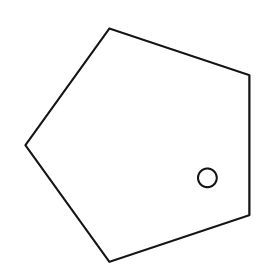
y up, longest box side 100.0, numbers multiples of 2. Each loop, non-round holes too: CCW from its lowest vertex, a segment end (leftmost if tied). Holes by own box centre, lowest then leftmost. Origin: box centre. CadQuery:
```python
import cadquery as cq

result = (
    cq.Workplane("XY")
    .moveTo(-12.0, -50.0)
    .lineTo(48.0, -30.0)
    .lineTo(48.0, 30.0)
    .lineTo(-12.0, 50.0)
    .lineTo(-48.0, 0.0)
    .close()
    .moveTo(30.0, -14.0)
    .circle(4.0)
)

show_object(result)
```